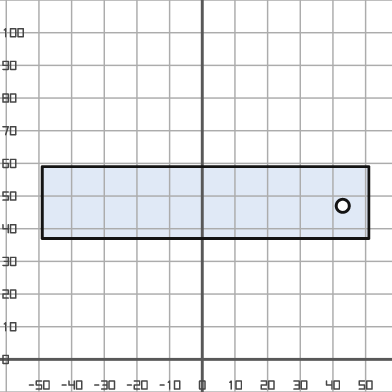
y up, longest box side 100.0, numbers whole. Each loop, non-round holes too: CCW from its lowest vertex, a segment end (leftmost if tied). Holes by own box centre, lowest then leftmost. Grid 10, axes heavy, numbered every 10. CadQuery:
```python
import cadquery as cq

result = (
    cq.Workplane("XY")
    .moveTo(-49.0, 37.0)
    .lineTo(51.0, 37.0)
    .lineTo(51.0, 59.0)
    .lineTo(-49.0, 59.0)
    .close()
    .moveTo(43.0, 47.0)
    .circle(2.0)
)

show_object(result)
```